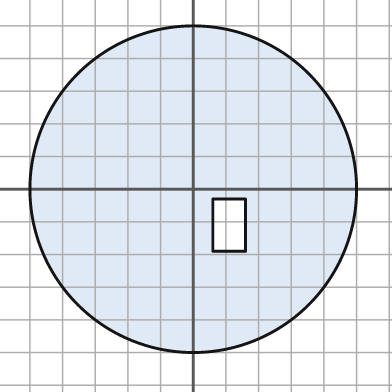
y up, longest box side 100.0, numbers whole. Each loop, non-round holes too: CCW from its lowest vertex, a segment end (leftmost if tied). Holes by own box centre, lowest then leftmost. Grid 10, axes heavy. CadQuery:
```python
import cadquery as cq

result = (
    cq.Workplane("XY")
    .moveTo(0.0, 0.0)
    .circle(50.0)
    .moveTo(6.0, -19.0)
    .lineTo(16.0, -19.0)
    .lineTo(16.0, -3.0)
    .lineTo(6.0, -3.0)
    .close()
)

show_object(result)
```